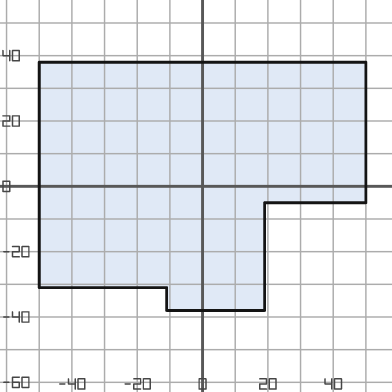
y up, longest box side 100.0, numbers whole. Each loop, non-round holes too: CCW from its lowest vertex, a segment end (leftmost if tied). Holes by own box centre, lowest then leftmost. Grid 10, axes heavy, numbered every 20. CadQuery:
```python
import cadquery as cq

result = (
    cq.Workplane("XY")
    .moveTo(-11.0, -38.0)
    .lineTo(19.0, -38.0)
    .lineTo(19.0, -5.0)
    .lineTo(50.0, -5.0)
    .lineTo(50.0, 38.0)
    .lineTo(-50.0, 38.0)
    .lineTo(-50.0, -31.0)
    .lineTo(-11.0, -31.0)
    .close()
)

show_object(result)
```